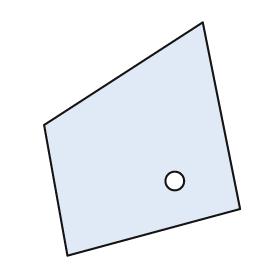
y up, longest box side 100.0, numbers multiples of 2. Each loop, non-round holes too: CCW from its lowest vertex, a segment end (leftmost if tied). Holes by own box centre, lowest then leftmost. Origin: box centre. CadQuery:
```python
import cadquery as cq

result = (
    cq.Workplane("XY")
    .moveTo(-32.0, -50.0)
    .lineTo(42.0, -30.0)
    .lineTo(26.0, 50.0)
    .lineTo(-42.0, 6.0)
    .close()
    .moveTo(14.0, -18.0)
    .circle(4.0)
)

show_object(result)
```